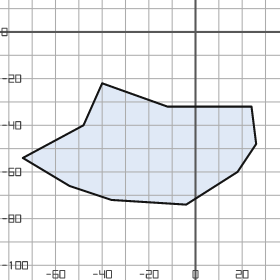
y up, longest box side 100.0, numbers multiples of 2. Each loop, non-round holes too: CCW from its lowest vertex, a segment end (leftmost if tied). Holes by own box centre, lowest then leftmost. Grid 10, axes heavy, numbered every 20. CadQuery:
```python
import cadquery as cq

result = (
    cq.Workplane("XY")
    .moveTo(-4.0, -74.0)
    .lineTo(18.0, -60.0)
    .lineTo(26.0, -48.0)
    .lineTo(24.0, -32.0)
    .lineTo(-12.0, -32.0)
    .lineTo(-40.0, -22.0)
    .lineTo(-48.0, -40.0)
    .lineTo(-74.0, -54.0)
    .lineTo(-54.0, -66.0)
    .lineTo(-36.0, -72.0)
    .close()
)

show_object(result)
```